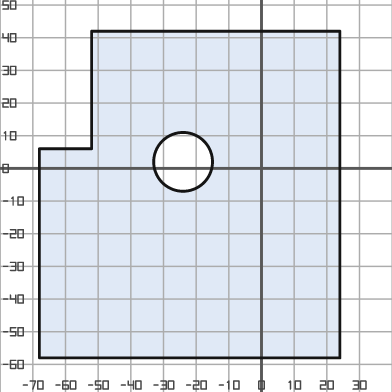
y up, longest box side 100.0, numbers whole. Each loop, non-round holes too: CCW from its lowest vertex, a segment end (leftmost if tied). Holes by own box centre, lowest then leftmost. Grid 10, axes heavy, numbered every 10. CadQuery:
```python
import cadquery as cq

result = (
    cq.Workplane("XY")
    .moveTo(-68.0, -58.0)
    .lineTo(24.0, -58.0)
    .lineTo(24.0, 42.0)
    .lineTo(-52.0, 42.0)
    .lineTo(-52.0, 6.0)
    .lineTo(-68.0, 6.0)
    .close()
    .moveTo(-24.0, 2.0)
    .circle(9.0)
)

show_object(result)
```